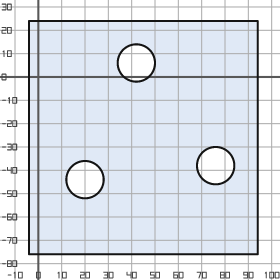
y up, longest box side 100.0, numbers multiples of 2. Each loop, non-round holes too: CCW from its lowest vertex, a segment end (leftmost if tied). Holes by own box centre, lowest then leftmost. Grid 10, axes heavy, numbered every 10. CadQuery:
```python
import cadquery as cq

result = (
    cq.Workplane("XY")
    .moveTo(-4.0, -76.0)
    .lineTo(94.0, -76.0)
    .lineTo(94.0, 24.0)
    .lineTo(-4.0, 24.0)
    .close()
    .moveTo(20.0, -44.0)
    .circle(8.0)
    .moveTo(76.0, -38.0)
    .circle(8.0)
    .moveTo(42.0, 6.0)
    .circle(8.0)
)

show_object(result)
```